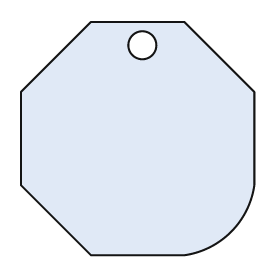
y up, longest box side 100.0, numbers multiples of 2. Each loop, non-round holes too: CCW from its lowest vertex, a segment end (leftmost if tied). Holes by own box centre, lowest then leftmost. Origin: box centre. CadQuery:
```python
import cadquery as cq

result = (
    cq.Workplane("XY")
    .moveTo(-20.0, -50.0)
    .lineTo(20.0, -50.0)
    .threePointArc((40.0, -40.0), (50.0, -20.0))
    .lineTo(50.0, 20.0)
    .lineTo(20.0, 50.0)
    .lineTo(-20.0, 50.0)
    .lineTo(-50.0, 20.0)
    .lineTo(-50.0, -20.0)
    .close()
    .moveTo(2.0, 40.0)
    .circle(6.0)
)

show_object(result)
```